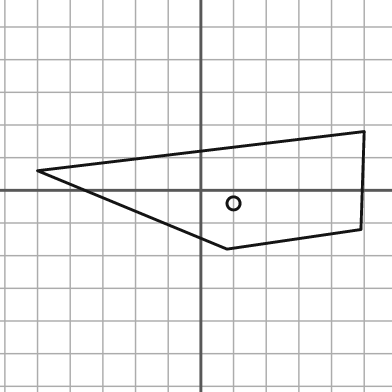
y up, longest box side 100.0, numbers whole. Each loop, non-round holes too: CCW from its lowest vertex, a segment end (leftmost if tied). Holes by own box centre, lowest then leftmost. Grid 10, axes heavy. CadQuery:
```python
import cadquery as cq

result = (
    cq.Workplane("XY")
    .moveTo(8.0, -18.0)
    .lineTo(49.0, -12.0)
    .lineTo(50.0, 18.0)
    .lineTo(-50.0, 6.0)
    .close()
    .moveTo(10.0, -4.0)
    .circle(2.0)
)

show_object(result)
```